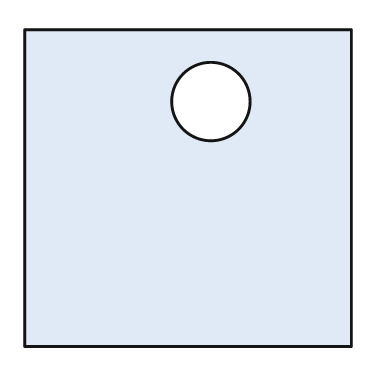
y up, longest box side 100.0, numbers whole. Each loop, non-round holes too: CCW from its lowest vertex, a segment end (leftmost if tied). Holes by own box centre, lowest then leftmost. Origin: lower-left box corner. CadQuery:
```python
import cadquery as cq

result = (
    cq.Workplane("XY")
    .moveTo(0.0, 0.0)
    .lineTo(100.0, 0.0)
    .lineTo(100.0, 97.0)
    .lineTo(0.0, 97.0)
    .close()
    .moveTo(57.0, 75.0)
    .circle(12.0)
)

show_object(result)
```